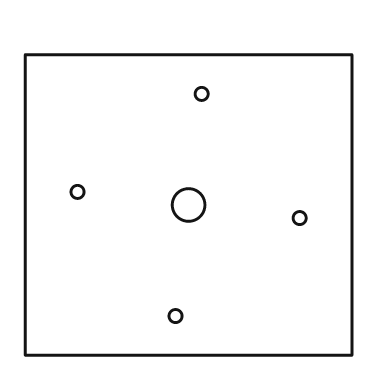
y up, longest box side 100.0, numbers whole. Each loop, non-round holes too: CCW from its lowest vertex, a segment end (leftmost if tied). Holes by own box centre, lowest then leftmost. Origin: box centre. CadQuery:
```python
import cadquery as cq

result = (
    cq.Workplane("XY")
    .moveTo(-50.0, -46.0)
    .lineTo(50.0, -46.0)
    .lineTo(50.0, 46.0)
    .lineTo(-50.0, 46.0)
    .close()
    .moveTo(-4.0, -34.0)
    .circle(2.0)
    .moveTo(34.0, -4.0)
    .circle(2.0)
    .moveTo(0.0, 0.0)
    .circle(5.0)
    .moveTo(-34.0, 4.0)
    .circle(2.0)
    .moveTo(4.0, 34.0)
    .circle(2.0)
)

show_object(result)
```